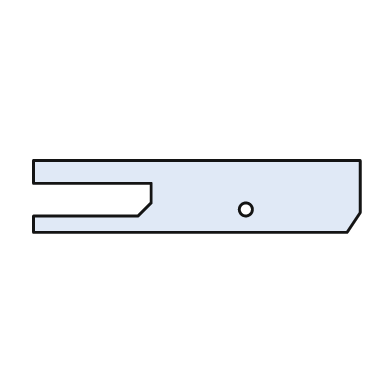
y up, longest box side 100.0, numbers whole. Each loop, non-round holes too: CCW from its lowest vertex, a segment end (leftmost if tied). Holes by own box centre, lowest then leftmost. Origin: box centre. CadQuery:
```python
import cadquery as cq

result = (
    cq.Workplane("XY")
    .moveTo(-50.0, -11.0)
    .lineTo(46.0, -11.0)
    .lineTo(50.0, -5.0)
    .lineTo(50.0, 11.0)
    .lineTo(-50.0, 11.0)
    .lineTo(-50.0, 4.0)
    .lineTo(-14.0, 4.0)
    .lineTo(-14.0, -2.0)
    .lineTo(-18.0, -6.0)
    .lineTo(-50.0, -6.0)
    .close()
    .moveTo(15.0, -4.0)
    .circle(2.0)
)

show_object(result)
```